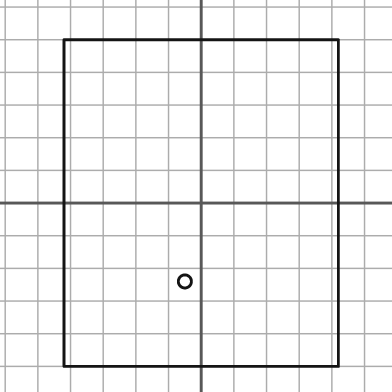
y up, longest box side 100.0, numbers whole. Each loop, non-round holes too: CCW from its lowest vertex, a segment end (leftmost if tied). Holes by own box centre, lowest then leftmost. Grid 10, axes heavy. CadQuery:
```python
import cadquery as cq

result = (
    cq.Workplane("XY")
    .moveTo(-42.0, -50.0)
    .lineTo(42.0, -50.0)
    .lineTo(42.0, 50.0)
    .lineTo(-42.0, 50.0)
    .close()
    .moveTo(-5.0, -24.0)
    .circle(2.0)
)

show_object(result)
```